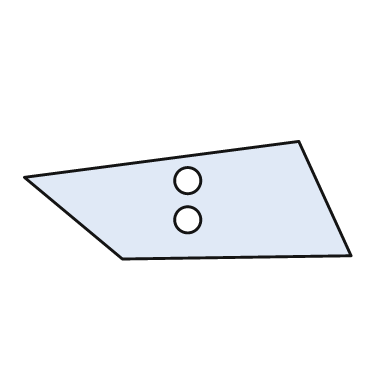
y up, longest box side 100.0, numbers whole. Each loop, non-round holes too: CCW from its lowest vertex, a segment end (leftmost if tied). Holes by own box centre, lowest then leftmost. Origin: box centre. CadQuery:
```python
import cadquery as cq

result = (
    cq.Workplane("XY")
    .moveTo(-20.0, -18.0)
    .lineTo(50.0, -17.0)
    .lineTo(34.0, 18.0)
    .lineTo(-50.0, 7.0)
    .close()
    .moveTo(0.0, -6.0)
    .circle(4.0)
    .moveTo(0.0, 6.0)
    .circle(4.0)
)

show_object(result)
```